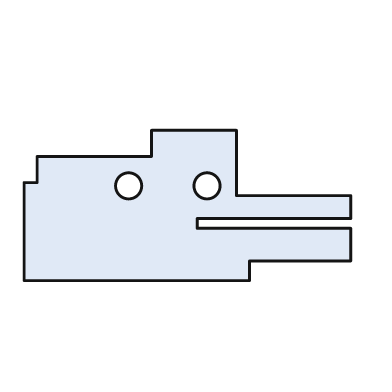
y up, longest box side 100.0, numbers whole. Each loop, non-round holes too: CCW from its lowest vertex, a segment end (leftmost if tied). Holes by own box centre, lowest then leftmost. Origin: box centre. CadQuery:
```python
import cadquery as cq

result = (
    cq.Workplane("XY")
    .moveTo(-50.0, -23.0)
    .lineTo(19.0, -23.0)
    .lineTo(19.0, -17.0)
    .lineTo(50.0, -17.0)
    .lineTo(50.0, -7.0)
    .lineTo(3.0, -7.0)
    .lineTo(3.0, -4.0)
    .lineTo(50.0, -4.0)
    .lineTo(50.0, 3.0)
    .lineTo(15.0, 3.0)
    .lineTo(15.0, 23.0)
    .lineTo(-11.0, 23.0)
    .lineTo(-11.0, 15.0)
    .lineTo(-46.0, 15.0)
    .lineTo(-46.0, 7.0)
    .lineTo(-50.0, 7.0)
    .close()
    .moveTo(-18.0, 6.0)
    .circle(4.0)
    .moveTo(6.0, 6.0)
    .circle(4.0)
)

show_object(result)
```